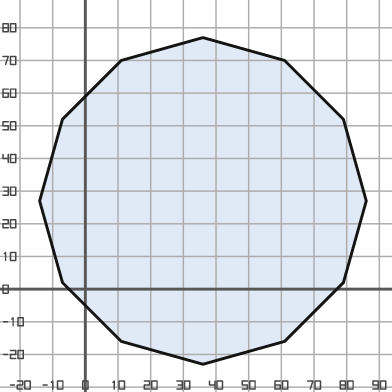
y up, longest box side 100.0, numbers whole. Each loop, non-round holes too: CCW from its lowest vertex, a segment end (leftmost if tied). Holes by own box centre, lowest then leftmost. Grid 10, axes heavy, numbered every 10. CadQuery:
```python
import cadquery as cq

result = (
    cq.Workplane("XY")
    .moveTo(36.0, -23.0)
    .lineTo(61.0, -16.0)
    .lineTo(79.0, 2.0)
    .lineTo(86.0, 27.0)
    .lineTo(79.0, 52.0)
    .lineTo(61.0, 70.0)
    .lineTo(36.0, 77.0)
    .lineTo(11.0, 70.0)
    .lineTo(-7.0, 52.0)
    .lineTo(-14.0, 27.0)
    .lineTo(-7.0, 2.0)
    .lineTo(11.0, -16.0)
    .close()
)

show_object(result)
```